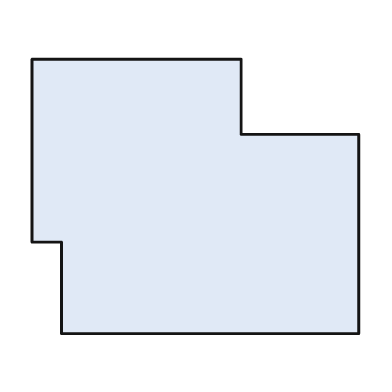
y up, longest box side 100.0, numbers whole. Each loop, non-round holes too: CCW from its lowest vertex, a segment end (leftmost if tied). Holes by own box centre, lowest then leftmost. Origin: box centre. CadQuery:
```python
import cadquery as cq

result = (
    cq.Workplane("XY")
    .moveTo(-41.0, -42.0)
    .lineTo(50.0, -42.0)
    .lineTo(50.0, 19.0)
    .lineTo(14.0, 19.0)
    .lineTo(14.0, 42.0)
    .lineTo(-50.0, 42.0)
    .lineTo(-50.0, -14.0)
    .lineTo(-41.0, -14.0)
    .close()
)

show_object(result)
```